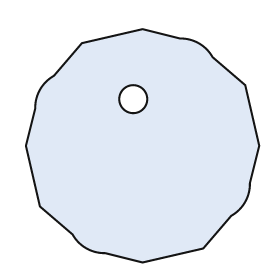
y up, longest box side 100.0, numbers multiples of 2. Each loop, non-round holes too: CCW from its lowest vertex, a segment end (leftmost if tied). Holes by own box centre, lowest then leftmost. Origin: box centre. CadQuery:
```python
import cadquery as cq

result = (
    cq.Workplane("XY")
    .moveTo(0.0, -50.0)
    .lineTo(26.0, -44.0)
    .lineTo(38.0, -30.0)
    .threePointArc((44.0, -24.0), (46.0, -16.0))
    .lineTo(50.0, 0.0)
    .lineTo(44.0, 26.0)
    .lineTo(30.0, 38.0)
    .threePointArc((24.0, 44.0), (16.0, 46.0))
    .lineTo(0.0, 50.0)
    .lineTo(-26.0, 44.0)
    .lineTo(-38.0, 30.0)
    .threePointArc((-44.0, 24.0), (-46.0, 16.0))
    .lineTo(-50.0, 0.0)
    .lineTo(-44.0, -26.0)
    .lineTo(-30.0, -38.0)
    .threePointArc((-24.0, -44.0), (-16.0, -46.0))
    .close()
    .moveTo(-4.0, 20.0)
    .circle(6.0)
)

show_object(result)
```